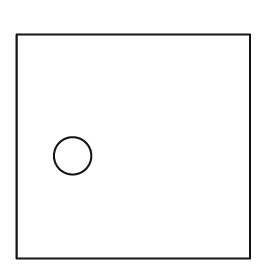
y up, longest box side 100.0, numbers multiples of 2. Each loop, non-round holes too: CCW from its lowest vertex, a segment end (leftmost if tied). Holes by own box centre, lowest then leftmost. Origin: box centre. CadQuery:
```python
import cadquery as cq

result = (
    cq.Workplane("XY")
    .moveTo(-50.0, -48.0)
    .lineTo(50.0, -48.0)
    .lineTo(50.0, 48.0)
    .lineTo(-50.0, 48.0)
    .close()
    .moveTo(-26.0, -4.0)
    .circle(8.0)
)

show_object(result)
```